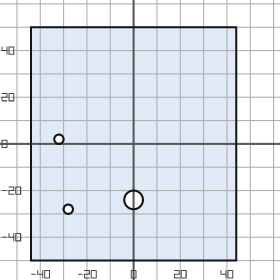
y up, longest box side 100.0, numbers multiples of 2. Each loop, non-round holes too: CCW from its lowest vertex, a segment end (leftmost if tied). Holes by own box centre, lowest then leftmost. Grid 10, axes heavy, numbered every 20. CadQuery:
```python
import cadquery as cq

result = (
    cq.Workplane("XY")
    .moveTo(-44.0, -50.0)
    .lineTo(44.0, -50.0)
    .lineTo(44.0, 50.0)
    .lineTo(-44.0, 50.0)
    .close()
    .moveTo(-28.0, -28.0)
    .circle(2.0)
    .moveTo(0.0, -24.0)
    .circle(4.0)
    .moveTo(-32.0, 2.0)
    .circle(2.0)
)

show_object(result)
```